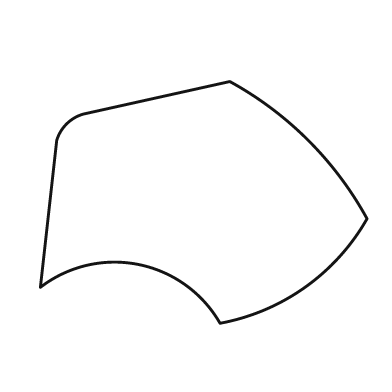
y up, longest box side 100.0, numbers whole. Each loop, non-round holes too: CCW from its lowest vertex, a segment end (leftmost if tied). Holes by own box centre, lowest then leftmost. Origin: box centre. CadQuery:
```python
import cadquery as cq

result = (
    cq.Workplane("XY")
    .moveTo(5.0, -37.0)
    .threePointArc((31.0, -26.0), (50.0, -5.0))
    .threePointArc((32.0, 19.0), (8.0, 37.0))
    .lineTo(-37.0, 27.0)
    .threePointArc((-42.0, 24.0), (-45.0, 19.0))
    .lineTo(-50.0, -26.0)
    .threePointArc((-20.0, -19.0), (5.0, -37.0))
    .close()
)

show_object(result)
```